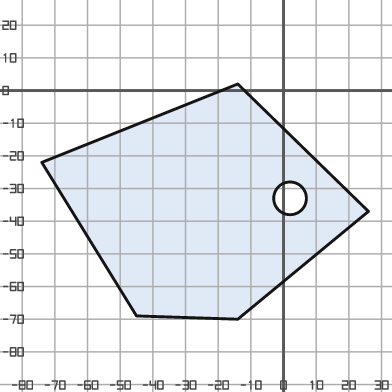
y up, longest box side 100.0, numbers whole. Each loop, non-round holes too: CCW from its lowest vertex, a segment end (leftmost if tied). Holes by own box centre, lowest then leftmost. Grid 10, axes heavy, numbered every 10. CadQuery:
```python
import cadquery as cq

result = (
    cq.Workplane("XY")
    .moveTo(-14.0, -70.0)
    .lineTo(26.0, -37.0)
    .lineTo(-14.0, 2.0)
    .lineTo(-74.0, -22.0)
    .lineTo(-45.0, -69.0)
    .close()
    .moveTo(2.0, -33.0)
    .circle(5.0)
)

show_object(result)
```